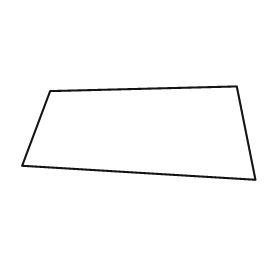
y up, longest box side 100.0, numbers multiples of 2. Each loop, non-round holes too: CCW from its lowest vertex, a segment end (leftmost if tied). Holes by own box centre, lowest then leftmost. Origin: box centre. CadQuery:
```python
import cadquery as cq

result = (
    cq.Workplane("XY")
    .moveTo(50.0, -20.0)
    .lineTo(42.0, 20.0)
    .lineTo(-38.0, 18.0)
    .lineTo(-50.0, -14.0)
    .close()
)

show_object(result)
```